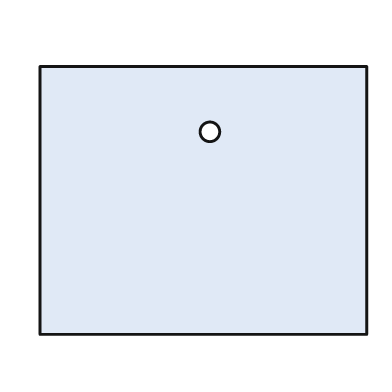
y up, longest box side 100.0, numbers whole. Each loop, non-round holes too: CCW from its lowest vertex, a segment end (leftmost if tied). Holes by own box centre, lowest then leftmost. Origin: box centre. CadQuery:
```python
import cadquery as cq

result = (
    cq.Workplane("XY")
    .moveTo(-50.0, -41.0)
    .lineTo(50.0, -41.0)
    .lineTo(50.0, 41.0)
    .lineTo(-50.0, 41.0)
    .close()
    .moveTo(2.0, 21.0)
    .circle(3.0)
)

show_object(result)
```